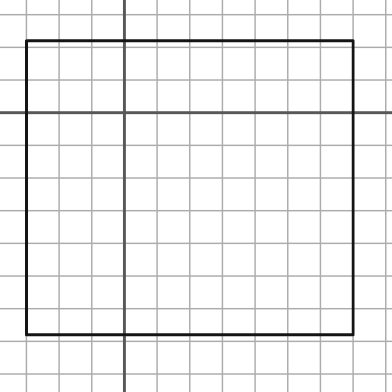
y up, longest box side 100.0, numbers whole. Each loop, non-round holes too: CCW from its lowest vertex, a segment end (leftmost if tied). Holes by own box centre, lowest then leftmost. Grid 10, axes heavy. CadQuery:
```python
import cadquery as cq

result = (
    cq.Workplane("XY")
    .moveTo(-30.0, -68.0)
    .lineTo(70.0, -68.0)
    .lineTo(70.0, 22.0)
    .lineTo(-30.0, 22.0)
    .close()
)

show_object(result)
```